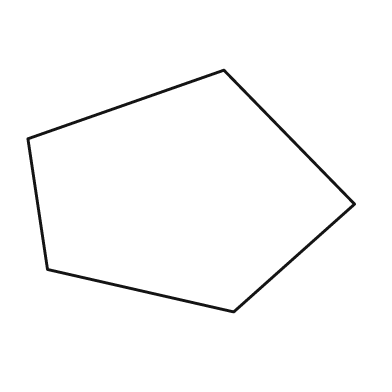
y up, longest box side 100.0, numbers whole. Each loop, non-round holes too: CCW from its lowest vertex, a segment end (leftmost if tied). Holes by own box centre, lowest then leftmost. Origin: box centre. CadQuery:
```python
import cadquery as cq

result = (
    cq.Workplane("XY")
    .moveTo(13.0, -37.0)
    .lineTo(50.0, -4.0)
    .lineTo(10.0, 37.0)
    .lineTo(-50.0, 16.0)
    .lineTo(-44.0, -24.0)
    .close()
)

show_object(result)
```